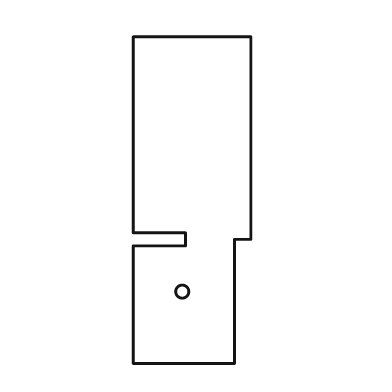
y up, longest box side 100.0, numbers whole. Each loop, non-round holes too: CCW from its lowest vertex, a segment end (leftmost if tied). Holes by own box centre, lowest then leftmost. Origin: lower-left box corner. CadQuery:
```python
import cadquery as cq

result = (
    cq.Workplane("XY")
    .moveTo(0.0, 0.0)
    .lineTo(31.0, 0.0)
    .lineTo(31.0, 38.0)
    .lineTo(36.0, 38.0)
    .lineTo(36.0, 100.0)
    .lineTo(0.0, 100.0)
    .lineTo(0.0, 40.0)
    .lineTo(16.0, 40.0)
    .lineTo(16.0, 36.0)
    .lineTo(0.0, 36.0)
    .close()
    .moveTo(15.0, 22.0)
    .circle(2.0)
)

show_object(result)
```